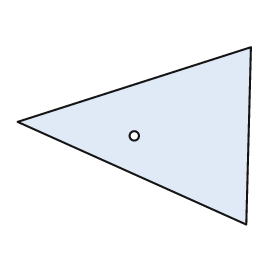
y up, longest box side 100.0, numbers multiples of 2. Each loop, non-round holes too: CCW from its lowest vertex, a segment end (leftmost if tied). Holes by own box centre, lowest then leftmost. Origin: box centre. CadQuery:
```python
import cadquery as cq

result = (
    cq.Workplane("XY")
    .moveTo(48.0, -38.0)
    .lineTo(50.0, 38.0)
    .lineTo(-50.0, 6.0)
    .close()
    .moveTo(0.0, 0.0)
    .circle(2.0)
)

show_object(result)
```